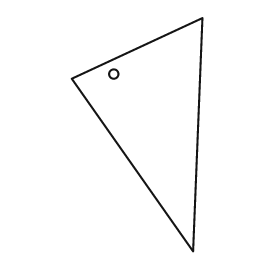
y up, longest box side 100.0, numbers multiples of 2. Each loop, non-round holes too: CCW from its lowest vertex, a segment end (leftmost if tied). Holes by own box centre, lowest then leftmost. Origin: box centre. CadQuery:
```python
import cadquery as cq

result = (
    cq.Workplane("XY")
    .moveTo(24.0, -50.0)
    .lineTo(28.0, 50.0)
    .lineTo(-28.0, 24.0)
    .close()
    .moveTo(-10.0, 26.0)
    .circle(2.0)
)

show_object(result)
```